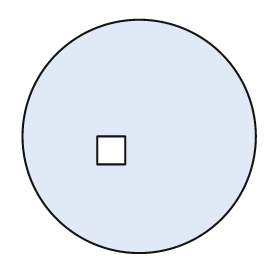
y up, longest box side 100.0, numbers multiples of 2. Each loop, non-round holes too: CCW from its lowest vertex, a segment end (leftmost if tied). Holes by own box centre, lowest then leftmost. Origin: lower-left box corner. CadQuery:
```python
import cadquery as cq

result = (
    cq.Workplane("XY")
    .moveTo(50.0, 50.0)
    .circle(50.0)
    .moveTo(32.0, 38.0)
    .lineTo(44.0, 38.0)
    .lineTo(44.0, 50.0)
    .lineTo(32.0, 50.0)
    .close()
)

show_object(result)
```